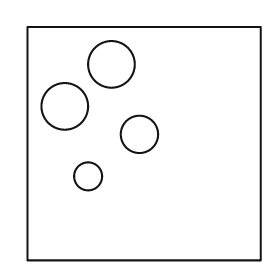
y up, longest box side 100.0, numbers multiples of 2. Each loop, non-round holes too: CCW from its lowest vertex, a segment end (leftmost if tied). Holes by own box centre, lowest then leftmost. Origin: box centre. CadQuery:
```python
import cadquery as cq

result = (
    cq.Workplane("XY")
    .moveTo(-50.0, -50.0)
    .lineTo(50.0, -50.0)
    .lineTo(50.0, 50.0)
    .lineTo(-50.0, 50.0)
    .close()
    .moveTo(-24.0, -14.0)
    .circle(6.0)
    .moveTo(-2.0, 4.0)
    .circle(8.0)
    .moveTo(-34.0, 16.0)
    .circle(10.0)
    .moveTo(-14.0, 34.0)
    .circle(10.0)
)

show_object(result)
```